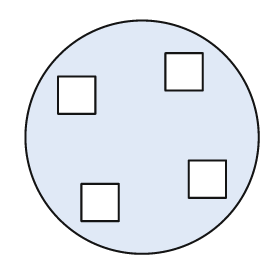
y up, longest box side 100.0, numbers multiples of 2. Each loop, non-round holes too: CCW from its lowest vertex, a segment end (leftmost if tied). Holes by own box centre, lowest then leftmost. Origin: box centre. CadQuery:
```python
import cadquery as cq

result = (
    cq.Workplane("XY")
    .moveTo(0.0, 0.0)
    .circle(50.0)
    .moveTo(-26.0, -36.0)
    .lineTo(-10.0, -36.0)
    .lineTo(-10.0, -20.0)
    .lineTo(-26.0, -20.0)
    .close()
    .moveTo(20.0, -26.0)
    .lineTo(36.0, -26.0)
    .lineTo(36.0, -10.0)
    .lineTo(20.0, -10.0)
    .close()
    .moveTo(-36.0, 10.0)
    .lineTo(-20.0, 10.0)
    .lineTo(-20.0, 26.0)
    .lineTo(-36.0, 26.0)
    .close()
    .moveTo(10.0, 20.0)
    .lineTo(26.0, 20.0)
    .lineTo(26.0, 36.0)
    .lineTo(10.0, 36.0)
    .close()
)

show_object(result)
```